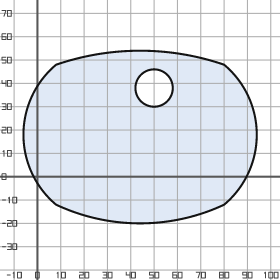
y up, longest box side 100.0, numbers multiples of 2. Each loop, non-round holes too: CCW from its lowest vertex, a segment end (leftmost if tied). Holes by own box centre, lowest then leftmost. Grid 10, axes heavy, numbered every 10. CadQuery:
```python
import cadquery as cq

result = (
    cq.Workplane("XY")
    .moveTo(8.0, -12.0)
    .threePointArc((44.0, -20.0), (80.0, -12.0))
    .threePointArc((94.0, 18.0), (80.0, 48.0))
    .threePointArc((44.0, 54.0), (8.0, 48.0))
    .threePointArc((-6.0, 18.0), (8.0, -12.0))
    .close()
    .moveTo(50.0, 38.0)
    .circle(8.0)
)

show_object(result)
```